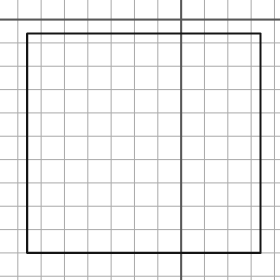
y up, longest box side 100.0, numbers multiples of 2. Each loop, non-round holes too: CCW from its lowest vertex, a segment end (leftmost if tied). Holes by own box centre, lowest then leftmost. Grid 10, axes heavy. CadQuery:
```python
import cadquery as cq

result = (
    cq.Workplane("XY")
    .moveTo(-66.0, -100.0)
    .lineTo(34.0, -100.0)
    .lineTo(34.0, -6.0)
    .lineTo(-66.0, -6.0)
    .close()
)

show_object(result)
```